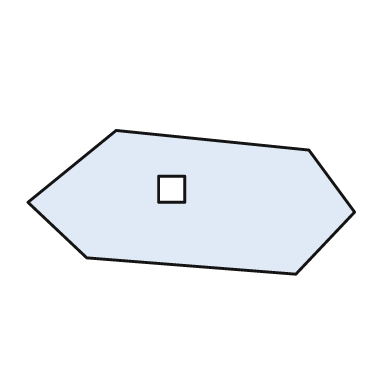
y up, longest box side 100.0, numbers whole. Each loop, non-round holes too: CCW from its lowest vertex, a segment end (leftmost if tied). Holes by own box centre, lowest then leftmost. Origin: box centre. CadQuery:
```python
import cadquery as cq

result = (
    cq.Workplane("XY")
    .moveTo(32.0, -22.0)
    .lineTo(50.0, -3.0)
    .lineTo(36.0, 16.0)
    .lineTo(-23.0, 22.0)
    .lineTo(-50.0, 0.0)
    .lineTo(-32.0, -17.0)
    .close()
    .moveTo(-10.0, 0.0)
    .lineTo(-2.0, 0.0)
    .lineTo(-2.0, 8.0)
    .lineTo(-10.0, 8.0)
    .close()
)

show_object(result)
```